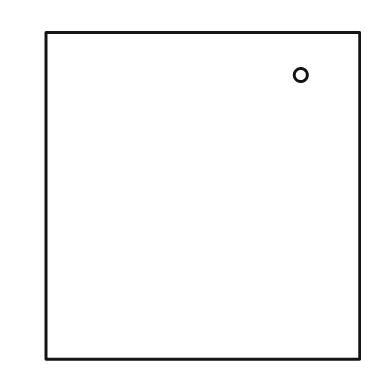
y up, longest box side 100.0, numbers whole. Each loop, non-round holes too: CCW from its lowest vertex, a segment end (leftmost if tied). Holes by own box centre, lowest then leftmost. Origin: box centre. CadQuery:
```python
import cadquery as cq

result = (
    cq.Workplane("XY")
    .moveTo(-48.0, -50.0)
    .lineTo(48.0, -50.0)
    .lineTo(48.0, 50.0)
    .lineTo(-48.0, 50.0)
    .close()
    .moveTo(30.0, 37.0)
    .circle(2.0)
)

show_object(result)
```